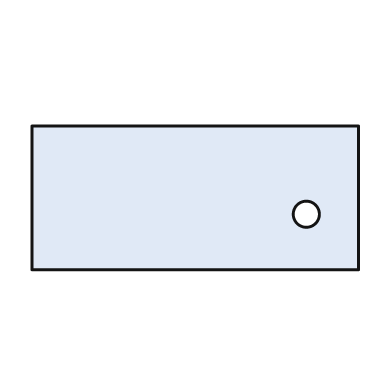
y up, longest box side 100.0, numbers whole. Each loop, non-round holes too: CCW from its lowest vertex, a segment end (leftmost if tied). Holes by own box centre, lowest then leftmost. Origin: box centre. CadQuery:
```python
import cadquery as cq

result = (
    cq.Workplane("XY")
    .moveTo(-50.0, -22.0)
    .lineTo(50.0, -22.0)
    .lineTo(50.0, 22.0)
    .lineTo(-50.0, 22.0)
    .close()
    .moveTo(34.0, -5.0)
    .circle(4.0)
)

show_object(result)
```